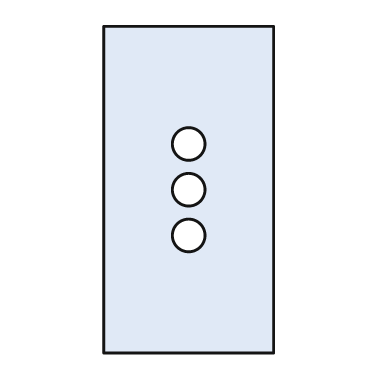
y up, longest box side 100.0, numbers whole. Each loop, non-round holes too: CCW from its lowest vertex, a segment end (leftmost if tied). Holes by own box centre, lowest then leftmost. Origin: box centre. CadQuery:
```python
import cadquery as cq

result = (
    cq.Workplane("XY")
    .moveTo(-26.0, -50.0)
    .lineTo(26.0, -50.0)
    .lineTo(26.0, 50.0)
    .lineTo(-26.0, 50.0)
    .close()
    .moveTo(0.0, -14.0)
    .circle(5.0)
    .moveTo(0.0, 0.0)
    .circle(5.0)
    .moveTo(0.0, 14.0)
    .circle(5.0)
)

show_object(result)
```